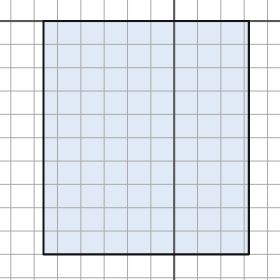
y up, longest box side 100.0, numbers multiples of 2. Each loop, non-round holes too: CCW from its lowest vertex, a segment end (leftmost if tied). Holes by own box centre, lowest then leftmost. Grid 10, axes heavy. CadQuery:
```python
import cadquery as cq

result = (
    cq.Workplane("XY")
    .moveTo(-56.0, -100.0)
    .lineTo(32.0, -100.0)
    .lineTo(32.0, 0.0)
    .lineTo(-56.0, 0.0)
    .close()
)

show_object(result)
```